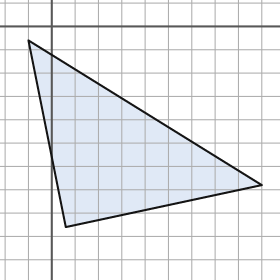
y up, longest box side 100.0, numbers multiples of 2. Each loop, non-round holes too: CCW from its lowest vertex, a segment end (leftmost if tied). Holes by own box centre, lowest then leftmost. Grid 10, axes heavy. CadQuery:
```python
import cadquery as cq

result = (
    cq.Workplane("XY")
    .moveTo(6.0, -86.0)
    .lineTo(90.0, -68.0)
    .lineTo(-10.0, -6.0)
    .close()
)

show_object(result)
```